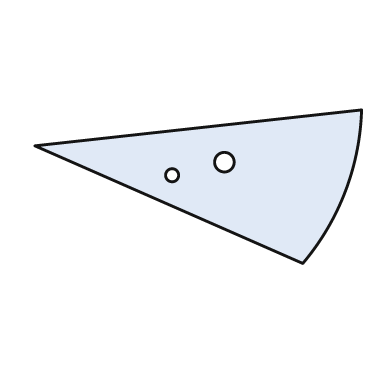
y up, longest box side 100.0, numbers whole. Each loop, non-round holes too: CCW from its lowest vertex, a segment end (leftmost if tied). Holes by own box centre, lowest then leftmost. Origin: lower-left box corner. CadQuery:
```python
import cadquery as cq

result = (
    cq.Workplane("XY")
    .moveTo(82.0, 0.0)
    .threePointArc((95.0, 22.0), (100.0, 47.0))
    .lineTo(0.0, 36.0)
    .close()
    .moveTo(42.0, 27.0)
    .circle(2.0)
    .moveTo(58.0, 31.0)
    .circle(3.0)
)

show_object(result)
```